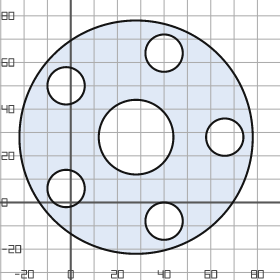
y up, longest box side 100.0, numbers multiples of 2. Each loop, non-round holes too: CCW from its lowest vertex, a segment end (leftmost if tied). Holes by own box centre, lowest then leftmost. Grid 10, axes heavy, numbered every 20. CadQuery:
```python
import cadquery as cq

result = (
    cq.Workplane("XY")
    .moveTo(28.0, 28.0)
    .circle(50.0)
    .moveTo(40.0, -8.0)
    .circle(8.0)
    .moveTo(-2.0, 6.0)
    .circle(8.0)
    .moveTo(28.0, 28.0)
    .circle(16.0)
    .moveTo(66.0, 28.0)
    .circle(8.0)
    .moveTo(-2.0, 50.0)
    .circle(8.0)
    .moveTo(40.0, 64.0)
    .circle(8.0)
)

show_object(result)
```